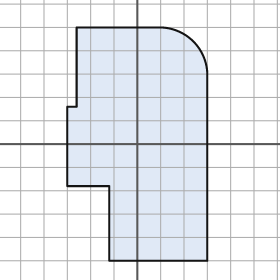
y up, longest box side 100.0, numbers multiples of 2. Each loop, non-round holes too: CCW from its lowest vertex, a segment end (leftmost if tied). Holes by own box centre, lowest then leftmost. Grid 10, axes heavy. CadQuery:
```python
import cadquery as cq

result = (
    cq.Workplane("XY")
    .moveTo(-12.0, -50.0)
    .lineTo(30.0, -50.0)
    .lineTo(30.0, 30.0)
    .threePointArc((24.0, 44.0), (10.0, 50.0))
    .lineTo(-26.0, 50.0)
    .lineTo(-26.0, 16.0)
    .lineTo(-30.0, 16.0)
    .lineTo(-30.0, -18.0)
    .lineTo(-12.0, -18.0)
    .close()
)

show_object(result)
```